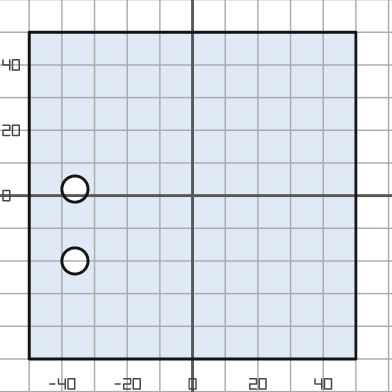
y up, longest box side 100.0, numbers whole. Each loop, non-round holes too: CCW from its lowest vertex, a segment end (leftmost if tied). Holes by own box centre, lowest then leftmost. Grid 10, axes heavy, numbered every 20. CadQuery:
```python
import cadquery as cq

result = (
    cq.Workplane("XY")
    .moveTo(-50.0, -50.0)
    .lineTo(50.0, -50.0)
    .lineTo(50.0, 50.0)
    .lineTo(-50.0, 50.0)
    .close()
    .moveTo(-36.0, -20.0)
    .circle(4.0)
    .moveTo(-36.0, 2.0)
    .circle(4.0)
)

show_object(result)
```